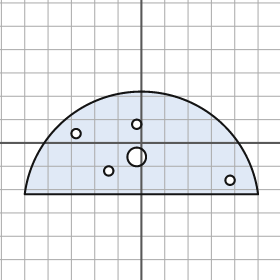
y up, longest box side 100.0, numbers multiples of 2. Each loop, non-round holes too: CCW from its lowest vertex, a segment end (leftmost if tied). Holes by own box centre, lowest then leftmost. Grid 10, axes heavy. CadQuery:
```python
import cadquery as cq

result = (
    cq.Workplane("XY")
    .moveTo(-50.0, -22.0)
    .lineTo(50.0, -22.0)
    .threePointArc((0.0, 22.0), (-50.0, -22.0))
    .close()
    .moveTo(38.0, -16.0)
    .circle(2.0)
    .moveTo(-14.0, -12.0)
    .circle(2.0)
    .moveTo(-2.0, -6.0)
    .circle(4.0)
    .moveTo(-28.0, 4.0)
    .circle(2.0)
    .moveTo(-2.0, 8.0)
    .circle(2.0)
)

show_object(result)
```